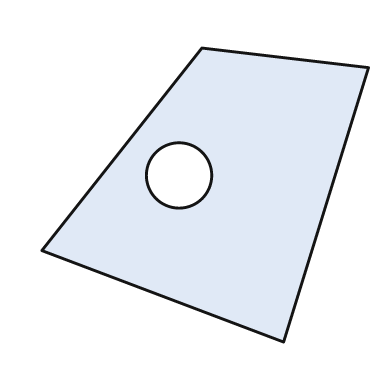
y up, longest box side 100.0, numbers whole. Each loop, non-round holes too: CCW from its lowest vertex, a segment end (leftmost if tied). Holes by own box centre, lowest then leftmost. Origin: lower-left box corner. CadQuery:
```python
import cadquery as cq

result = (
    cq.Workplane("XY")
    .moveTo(74.0, 0.0)
    .lineTo(100.0, 84.0)
    .lineTo(49.0, 90.0)
    .lineTo(0.0, 28.0)
    .close()
    .moveTo(42.0, 51.0)
    .circle(10.0)
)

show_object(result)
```